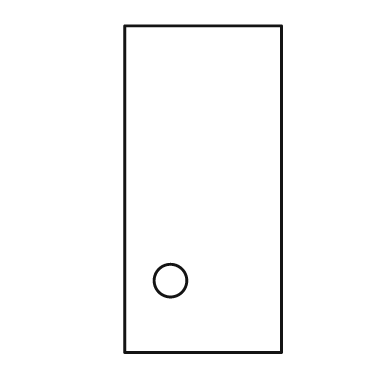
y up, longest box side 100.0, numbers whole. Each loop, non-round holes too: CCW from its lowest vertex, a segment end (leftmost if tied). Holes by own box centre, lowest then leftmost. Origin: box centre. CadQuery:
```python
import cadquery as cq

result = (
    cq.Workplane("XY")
    .moveTo(-24.0, -50.0)
    .lineTo(24.0, -50.0)
    .lineTo(24.0, 50.0)
    .lineTo(-24.0, 50.0)
    .close()
    .moveTo(-10.0, -28.0)
    .circle(5.0)
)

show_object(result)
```